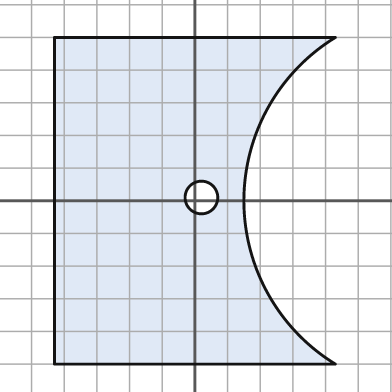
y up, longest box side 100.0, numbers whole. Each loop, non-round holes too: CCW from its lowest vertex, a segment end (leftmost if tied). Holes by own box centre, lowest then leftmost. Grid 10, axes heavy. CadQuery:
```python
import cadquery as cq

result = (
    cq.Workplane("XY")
    .moveTo(-43.0, -50.0)
    .lineTo(43.0, -50.0)
    .threePointArc((15.0, 0.0), (43.0, 50.0))
    .lineTo(-43.0, 50.0)
    .close()
    .moveTo(2.0, 1.0)
    .circle(5.0)
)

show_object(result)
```